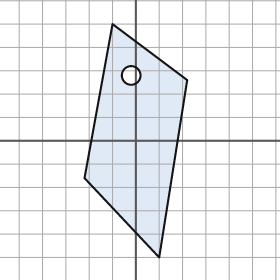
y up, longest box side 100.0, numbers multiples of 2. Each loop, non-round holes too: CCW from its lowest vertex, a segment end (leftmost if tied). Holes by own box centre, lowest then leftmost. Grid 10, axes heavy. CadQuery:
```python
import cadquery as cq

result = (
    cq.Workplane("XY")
    .moveTo(10.0, -50.0)
    .lineTo(22.0, 26.0)
    .lineTo(-10.0, 50.0)
    .lineTo(-22.0, -16.0)
    .close()
    .moveTo(-2.0, 28.0)
    .circle(4.0)
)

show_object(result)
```